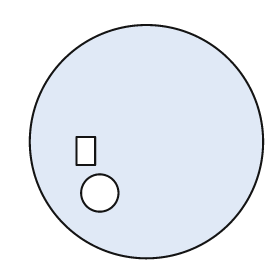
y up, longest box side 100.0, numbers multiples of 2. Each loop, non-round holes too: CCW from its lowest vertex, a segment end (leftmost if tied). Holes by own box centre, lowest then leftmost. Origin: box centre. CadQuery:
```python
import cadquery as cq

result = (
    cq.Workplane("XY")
    .moveTo(0.0, 0.0)
    .circle(50.0)
    .moveTo(-20.0, -22.0)
    .circle(8.0)
    .moveTo(-30.0, -10.0)
    .lineTo(-22.0, -10.0)
    .lineTo(-22.0, 2.0)
    .lineTo(-30.0, 2.0)
    .close()
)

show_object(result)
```